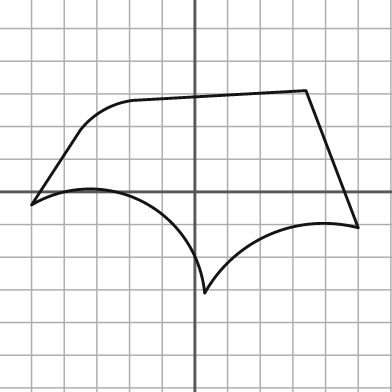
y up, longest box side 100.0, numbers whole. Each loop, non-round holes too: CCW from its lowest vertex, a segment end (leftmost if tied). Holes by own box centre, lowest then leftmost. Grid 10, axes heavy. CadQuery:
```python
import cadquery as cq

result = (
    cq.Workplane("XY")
    .moveTo(3.0, -31.0)
    .threePointArc((23.0, -13.0), (50.0, -11.0))
    .lineTo(34.0, 31.0)
    .lineTo(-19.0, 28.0)
    .threePointArc((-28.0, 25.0), (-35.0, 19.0))
    .lineTo(-50.0, -4.0)
    .threePointArc((-16.0, -3.0), (3.0, -31.0))
    .close()
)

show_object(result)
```